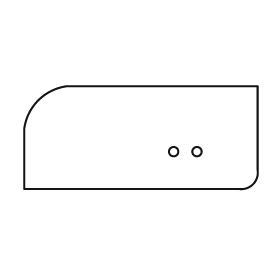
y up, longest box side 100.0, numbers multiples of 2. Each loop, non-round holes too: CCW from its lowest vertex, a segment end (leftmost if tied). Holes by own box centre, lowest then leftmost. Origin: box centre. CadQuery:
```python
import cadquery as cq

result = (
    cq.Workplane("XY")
    .moveTo(-50.0, -22.0)
    .lineTo(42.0, -22.0)
    .threePointArc((48.0, -20.0), (50.0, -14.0))
    .lineTo(50.0, 22.0)
    .lineTo(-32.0, 22.0)
    .threePointArc((-44.0, 16.0), (-50.0, 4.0))
    .close()
    .moveTo(14.0, -6.0)
    .circle(2.0)
    .moveTo(24.0, -6.0)
    .circle(2.0)
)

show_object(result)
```